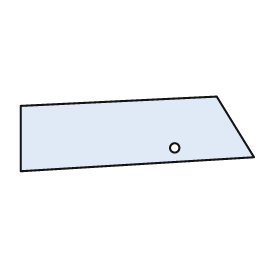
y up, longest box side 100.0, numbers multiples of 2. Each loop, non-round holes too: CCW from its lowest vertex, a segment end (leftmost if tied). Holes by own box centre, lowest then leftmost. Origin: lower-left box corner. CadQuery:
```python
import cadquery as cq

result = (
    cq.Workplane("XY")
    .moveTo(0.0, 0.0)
    .lineTo(100.0, 6.0)
    .lineTo(84.0, 32.0)
    .lineTo(0.0, 28.0)
    .close()
    .moveTo(66.0, 10.0)
    .circle(2.0)
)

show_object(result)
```